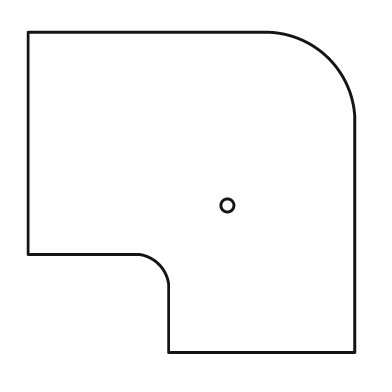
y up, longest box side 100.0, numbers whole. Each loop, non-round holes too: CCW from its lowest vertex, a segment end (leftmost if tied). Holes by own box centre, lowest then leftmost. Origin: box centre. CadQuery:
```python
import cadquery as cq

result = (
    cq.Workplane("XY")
    .moveTo(-7.0, -49.0)
    .lineTo(50.0, -49.0)
    .lineTo(50.0, 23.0)
    .threePointArc((42.0, 41.0), (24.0, 49.0))
    .lineTo(-50.0, 49.0)
    .lineTo(-50.0, -19.0)
    .lineTo(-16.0, -19.0)
    .threePointArc((-10.0, -22.0), (-7.0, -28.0))
    .close()
    .moveTo(11.0, -4.0)
    .circle(2.0)
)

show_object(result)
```